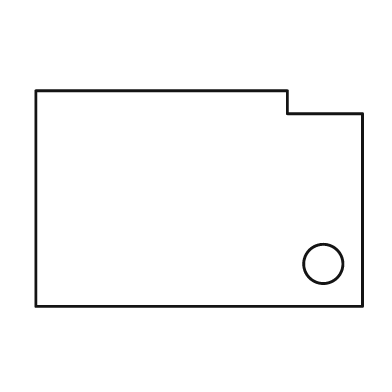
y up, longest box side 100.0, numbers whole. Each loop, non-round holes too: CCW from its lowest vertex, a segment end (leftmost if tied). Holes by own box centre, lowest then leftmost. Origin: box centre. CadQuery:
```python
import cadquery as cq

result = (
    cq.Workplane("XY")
    .moveTo(-50.0, -33.0)
    .lineTo(50.0, -33.0)
    .lineTo(50.0, 26.0)
    .lineTo(27.0, 26.0)
    .lineTo(27.0, 33.0)
    .lineTo(-50.0, 33.0)
    .close()
    .moveTo(38.0, -20.0)
    .circle(6.0)
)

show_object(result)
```